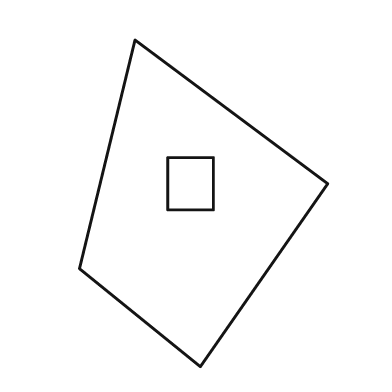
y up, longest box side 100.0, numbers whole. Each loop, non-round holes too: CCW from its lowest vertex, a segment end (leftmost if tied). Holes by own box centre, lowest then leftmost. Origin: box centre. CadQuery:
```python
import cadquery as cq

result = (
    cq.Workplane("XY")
    .moveTo(-1.0, -50.0)
    .lineTo(38.0, 6.0)
    .lineTo(-21.0, 50.0)
    .lineTo(-38.0, -20.0)
    .close()
    .moveTo(-11.0, -2.0)
    .lineTo(3.0, -2.0)
    .lineTo(3.0, 14.0)
    .lineTo(-11.0, 14.0)
    .close()
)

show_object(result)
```